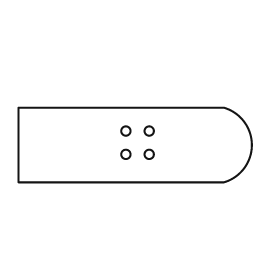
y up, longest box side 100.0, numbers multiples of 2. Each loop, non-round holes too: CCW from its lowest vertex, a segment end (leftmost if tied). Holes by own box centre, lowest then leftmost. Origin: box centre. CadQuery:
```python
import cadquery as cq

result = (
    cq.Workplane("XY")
    .moveTo(-50.0, -16.0)
    .lineTo(38.0, -16.0)
    .threePointArc((50.0, 0.0), (38.0, 16.0))
    .lineTo(-50.0, 16.0)
    .close()
    .moveTo(-4.0, -4.0)
    .circle(2.0)
    .moveTo(6.0, -4.0)
    .circle(2.0)
    .moveTo(-4.0, 6.0)
    .circle(2.0)
    .moveTo(6.0, 6.0)
    .circle(2.0)
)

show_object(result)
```